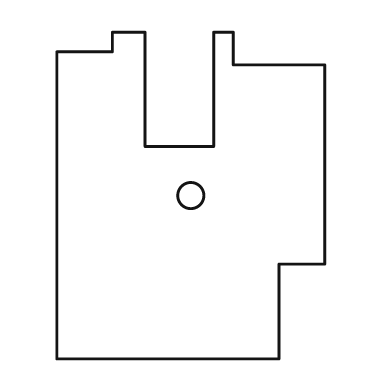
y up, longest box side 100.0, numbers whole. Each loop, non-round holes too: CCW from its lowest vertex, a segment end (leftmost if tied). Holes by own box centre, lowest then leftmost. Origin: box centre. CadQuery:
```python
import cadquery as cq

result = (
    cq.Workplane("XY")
    .moveTo(-41.0, -50.0)
    .lineTo(27.0, -50.0)
    .lineTo(27.0, -21.0)
    .lineTo(41.0, -21.0)
    .lineTo(41.0, 40.0)
    .lineTo(13.0, 40.0)
    .lineTo(13.0, 50.0)
    .lineTo(7.0, 50.0)
    .lineTo(7.0, 15.0)
    .lineTo(-14.0, 15.0)
    .lineTo(-14.0, 50.0)
    .lineTo(-24.0, 50.0)
    .lineTo(-24.0, 44.0)
    .lineTo(-41.0, 44.0)
    .close()
    .moveTo(0.0, 0.0)
    .circle(4.0)
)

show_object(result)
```